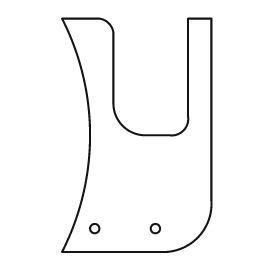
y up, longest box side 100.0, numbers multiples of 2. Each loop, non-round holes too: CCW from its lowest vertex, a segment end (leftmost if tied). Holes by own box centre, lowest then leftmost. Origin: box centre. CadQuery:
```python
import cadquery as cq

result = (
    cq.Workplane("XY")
    .moveTo(-32.0, -50.0)
    .lineTo(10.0, -50.0)
    .threePointArc((26.0, -44.0), (32.0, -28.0))
    .lineTo(32.0, 50.0)
    .lineTo(22.0, 50.0)
    .lineTo(22.0, 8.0)
    .threePointArc((20.0, 2.0), (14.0, 0.0))
    .lineTo(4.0, 0.0)
    .threePointArc((-6.0, 4.0), (-10.0, 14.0))
    .lineTo(-10.0, 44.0)
    .threePointArc((-12.0, 48.0), (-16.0, 50.0))
    .lineTo(-32.0, 50.0)
    .threePointArc((-20.0, 0.0), (-32.0, -50.0))
    .close()
    .moveTo(-18.0, -40.0)
    .circle(2.0)
    .moveTo(8.0, -40.0)
    .circle(2.0)
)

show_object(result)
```